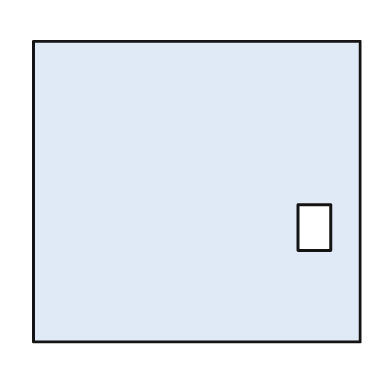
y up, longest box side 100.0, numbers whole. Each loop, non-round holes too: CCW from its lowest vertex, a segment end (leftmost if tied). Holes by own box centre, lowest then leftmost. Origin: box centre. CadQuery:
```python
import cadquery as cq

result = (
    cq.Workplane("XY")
    .moveTo(-50.0, -46.0)
    .lineTo(50.0, -46.0)
    .lineTo(50.0, 46.0)
    .lineTo(-50.0, 46.0)
    .close()
    .moveTo(31.0, -18.0)
    .lineTo(41.0, -18.0)
    .lineTo(41.0, -4.0)
    .lineTo(31.0, -4.0)
    .close()
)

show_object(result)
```